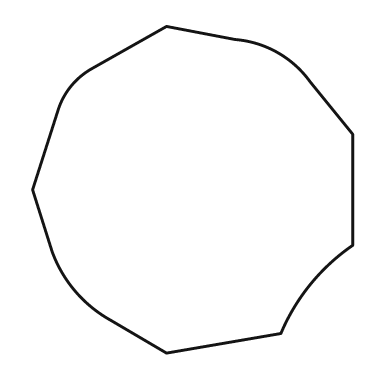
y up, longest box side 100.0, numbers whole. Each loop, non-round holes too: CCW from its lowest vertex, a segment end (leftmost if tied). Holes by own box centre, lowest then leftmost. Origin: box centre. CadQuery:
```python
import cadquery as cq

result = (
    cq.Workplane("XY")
    .moveTo(-8.0, -50.0)
    .lineTo(27.0, -44.0)
    .threePointArc((36.0, -29.0), (49.0, -17.0))
    .lineTo(49.0, 17.0)
    .lineTo(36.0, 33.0)
    .threePointArc((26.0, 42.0), (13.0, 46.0))
    .lineTo(-8.0, 50.0)
    .lineTo(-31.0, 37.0)
    .threePointArc((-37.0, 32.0), (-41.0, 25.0))
    .lineTo(-49.0, 0.0)
    .lineTo(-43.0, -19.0)
    .threePointArc((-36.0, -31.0), (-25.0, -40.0))
    .close()
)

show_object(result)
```